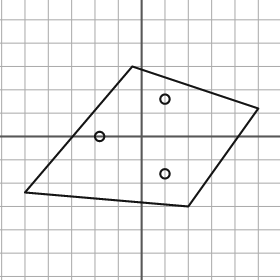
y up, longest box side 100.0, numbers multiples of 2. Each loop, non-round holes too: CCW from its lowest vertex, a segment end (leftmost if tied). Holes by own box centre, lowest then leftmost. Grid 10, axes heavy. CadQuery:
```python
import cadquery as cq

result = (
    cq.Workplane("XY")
    .moveTo(20.0, -30.0)
    .lineTo(50.0, 12.0)
    .lineTo(-4.0, 30.0)
    .lineTo(-50.0, -24.0)
    .close()
    .moveTo(10.0, -16.0)
    .circle(2.0)
    .moveTo(-18.0, 0.0)
    .circle(2.0)
    .moveTo(10.0, 16.0)
    .circle(2.0)
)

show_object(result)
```